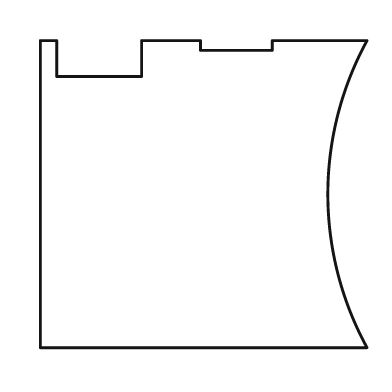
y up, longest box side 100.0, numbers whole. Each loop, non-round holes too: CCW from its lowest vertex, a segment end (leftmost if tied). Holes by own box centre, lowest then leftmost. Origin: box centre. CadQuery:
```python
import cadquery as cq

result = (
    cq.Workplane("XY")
    .moveTo(-50.0, -47.0)
    .lineTo(50.0, -47.0)
    .threePointArc((38.0, 0.0), (50.0, 47.0))
    .lineTo(21.0, 47.0)
    .lineTo(21.0, 44.0)
    .lineTo(-1.0, 44.0)
    .lineTo(-1.0, 47.0)
    .lineTo(-19.0, 47.0)
    .lineTo(-19.0, 36.0)
    .lineTo(-45.0, 36.0)
    .lineTo(-45.0, 47.0)
    .lineTo(-50.0, 47.0)
    .close()
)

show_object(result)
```